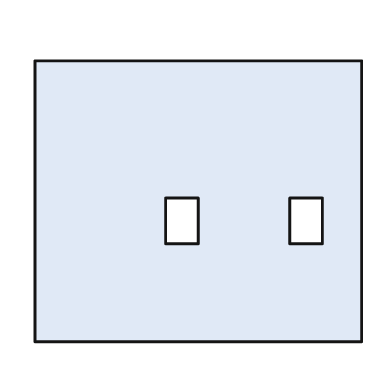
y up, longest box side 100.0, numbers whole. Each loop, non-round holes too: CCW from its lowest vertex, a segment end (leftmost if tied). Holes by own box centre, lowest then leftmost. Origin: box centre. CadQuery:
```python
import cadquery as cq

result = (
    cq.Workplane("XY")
    .moveTo(-50.0, -43.0)
    .lineTo(50.0, -43.0)
    .lineTo(50.0, 43.0)
    .lineTo(-50.0, 43.0)
    .close()
    .moveTo(-10.0, -13.0)
    .lineTo(0.0, -13.0)
    .lineTo(0.0, 1.0)
    .lineTo(-10.0, 1.0)
    .close()
    .moveTo(28.0, -13.0)
    .lineTo(38.0, -13.0)
    .lineTo(38.0, 1.0)
    .lineTo(28.0, 1.0)
    .close()
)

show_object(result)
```